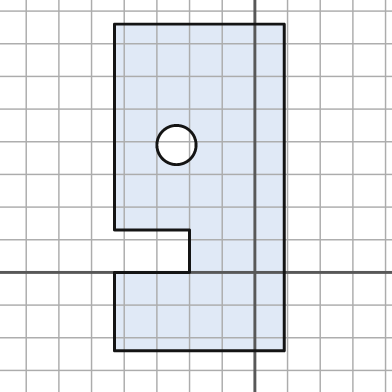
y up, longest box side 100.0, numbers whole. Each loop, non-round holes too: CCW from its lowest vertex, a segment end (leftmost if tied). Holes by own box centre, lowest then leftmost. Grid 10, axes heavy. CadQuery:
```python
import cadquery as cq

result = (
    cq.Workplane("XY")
    .moveTo(-43.0, -24.0)
    .lineTo(9.0, -24.0)
    .lineTo(9.0, 76.0)
    .lineTo(-43.0, 76.0)
    .lineTo(-43.0, 13.0)
    .lineTo(-20.0, 13.0)
    .lineTo(-20.0, 0.0)
    .lineTo(-43.0, 0.0)
    .close()
    .moveTo(-24.0, 39.0)
    .circle(6.0)
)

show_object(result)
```